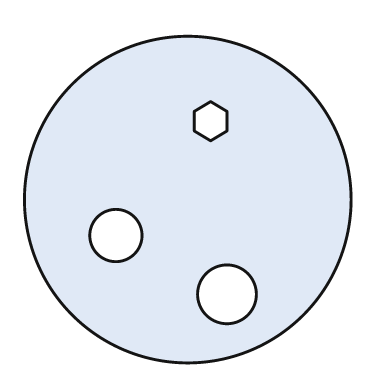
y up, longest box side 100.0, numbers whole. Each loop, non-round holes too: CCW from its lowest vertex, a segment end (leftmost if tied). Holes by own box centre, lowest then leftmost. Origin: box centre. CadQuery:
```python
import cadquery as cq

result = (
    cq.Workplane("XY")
    .moveTo(0.0, 0.0)
    .circle(50.0)
    .moveTo(12.0, -29.0)
    .circle(9.0)
    .moveTo(-22.0, -11.0)
    .circle(8.0)
    .moveTo(7.0, 18.0)
    .lineTo(12.0, 21.0)
    .lineTo(12.0, 27.0)
    .lineTo(7.0, 30.0)
    .lineTo(2.0, 27.0)
    .lineTo(2.0, 21.0)
    .close()
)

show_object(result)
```